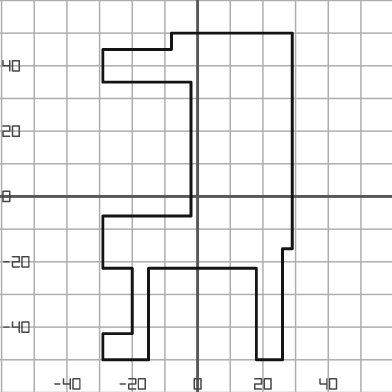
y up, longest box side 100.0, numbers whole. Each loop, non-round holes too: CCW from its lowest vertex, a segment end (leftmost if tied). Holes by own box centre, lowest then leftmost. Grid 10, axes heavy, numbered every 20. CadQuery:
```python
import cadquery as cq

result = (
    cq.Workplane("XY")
    .moveTo(-29.0, -50.0)
    .lineTo(-15.0, -50.0)
    .lineTo(-15.0, -22.0)
    .lineTo(18.0, -22.0)
    .lineTo(18.0, -50.0)
    .lineTo(26.0, -50.0)
    .lineTo(26.0, -16.0)
    .lineTo(29.0, -16.0)
    .lineTo(29.0, 50.0)
    .lineTo(-8.0, 50.0)
    .lineTo(-8.0, 45.0)
    .lineTo(-29.0, 45.0)
    .lineTo(-29.0, 35.0)
    .lineTo(-2.0, 35.0)
    .lineTo(-2.0, -6.0)
    .lineTo(-29.0, -6.0)
    .lineTo(-29.0, -22.0)
    .lineTo(-20.0, -22.0)
    .lineTo(-20.0, -42.0)
    .lineTo(-29.0, -42.0)
    .close()
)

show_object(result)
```